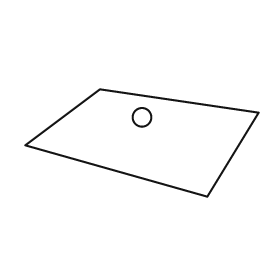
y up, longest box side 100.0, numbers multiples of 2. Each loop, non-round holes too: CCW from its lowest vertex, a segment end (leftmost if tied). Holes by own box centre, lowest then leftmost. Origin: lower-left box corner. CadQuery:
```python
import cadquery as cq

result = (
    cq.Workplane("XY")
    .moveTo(78.0, 0.0)
    .lineTo(100.0, 36.0)
    .lineTo(32.0, 46.0)
    .lineTo(0.0, 22.0)
    .close()
    .moveTo(50.0, 34.0)
    .circle(4.0)
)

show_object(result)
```